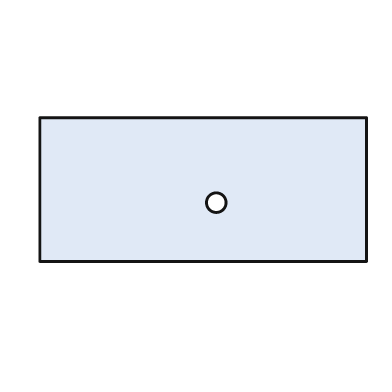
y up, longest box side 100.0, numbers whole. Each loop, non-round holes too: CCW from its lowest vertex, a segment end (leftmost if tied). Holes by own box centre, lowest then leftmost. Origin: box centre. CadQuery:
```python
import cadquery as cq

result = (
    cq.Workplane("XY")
    .moveTo(-50.0, -22.0)
    .lineTo(50.0, -22.0)
    .lineTo(50.0, 22.0)
    .lineTo(-50.0, 22.0)
    .close()
    .moveTo(4.0, -4.0)
    .circle(3.0)
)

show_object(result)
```